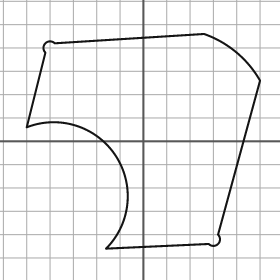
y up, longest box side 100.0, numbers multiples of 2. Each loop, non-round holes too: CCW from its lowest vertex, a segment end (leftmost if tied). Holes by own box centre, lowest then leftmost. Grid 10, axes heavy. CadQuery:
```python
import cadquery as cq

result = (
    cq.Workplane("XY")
    .moveTo(-16.0, -46.0)
    .lineTo(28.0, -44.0)
    .threePointArc((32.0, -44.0), (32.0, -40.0))
    .lineTo(50.0, 26.0)
    .threePointArc((40.0, 38.0), (26.0, 46.0))
    .lineTo(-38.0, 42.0)
    .threePointArc((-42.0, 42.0), (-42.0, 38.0))
    .lineTo(-50.0, 6.0)
    .threePointArc((-12.0, -6.0), (-16.0, -46.0))
    .close()
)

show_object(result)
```